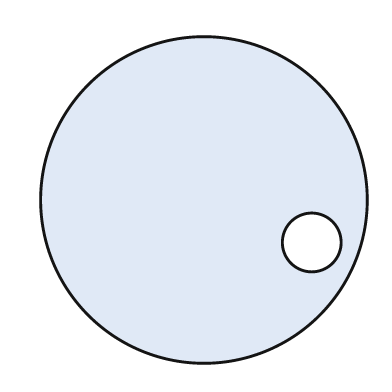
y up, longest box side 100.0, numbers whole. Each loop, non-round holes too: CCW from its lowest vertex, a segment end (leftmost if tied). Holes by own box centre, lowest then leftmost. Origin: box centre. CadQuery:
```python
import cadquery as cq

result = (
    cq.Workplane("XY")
    .moveTo(0.0, 0.0)
    .circle(50.0)
    .moveTo(33.0, -13.0)
    .circle(9.0)
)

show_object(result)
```